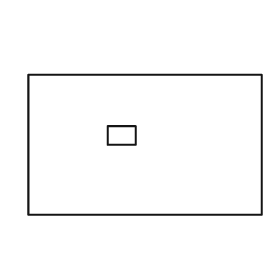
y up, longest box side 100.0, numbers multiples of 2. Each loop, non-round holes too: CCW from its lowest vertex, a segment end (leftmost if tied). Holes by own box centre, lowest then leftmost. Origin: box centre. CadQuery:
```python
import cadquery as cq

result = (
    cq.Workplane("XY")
    .moveTo(-50.0, -30.0)
    .lineTo(50.0, -30.0)
    .lineTo(50.0, 30.0)
    .lineTo(-50.0, 30.0)
    .close()
    .moveTo(-16.0, 0.0)
    .lineTo(-4.0, 0.0)
    .lineTo(-4.0, 8.0)
    .lineTo(-16.0, 8.0)
    .close()
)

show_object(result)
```